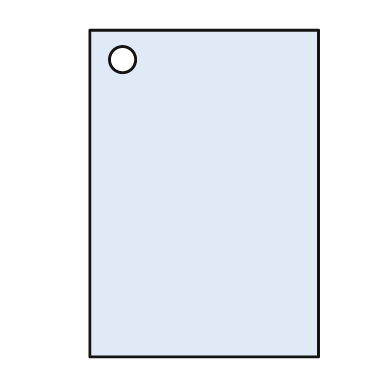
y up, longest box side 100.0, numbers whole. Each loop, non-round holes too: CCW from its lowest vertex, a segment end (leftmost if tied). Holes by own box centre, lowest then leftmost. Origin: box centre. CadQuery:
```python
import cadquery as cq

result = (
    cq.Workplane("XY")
    .moveTo(-35.0, -50.0)
    .lineTo(35.0, -50.0)
    .lineTo(35.0, 50.0)
    .lineTo(-35.0, 50.0)
    .close()
    .moveTo(-25.0, 41.0)
    .circle(4.0)
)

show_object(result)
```